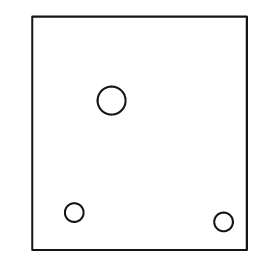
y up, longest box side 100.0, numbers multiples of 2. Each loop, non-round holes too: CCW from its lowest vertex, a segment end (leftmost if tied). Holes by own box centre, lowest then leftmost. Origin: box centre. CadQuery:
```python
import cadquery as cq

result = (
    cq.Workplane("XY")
    .moveTo(-46.0, -50.0)
    .lineTo(46.0, -50.0)
    .lineTo(46.0, 50.0)
    .lineTo(-46.0, 50.0)
    .close()
    .moveTo(36.0, -38.0)
    .circle(4.0)
    .moveTo(-28.0, -34.0)
    .circle(4.0)
    .moveTo(-12.0, 14.0)
    .circle(6.0)
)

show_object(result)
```